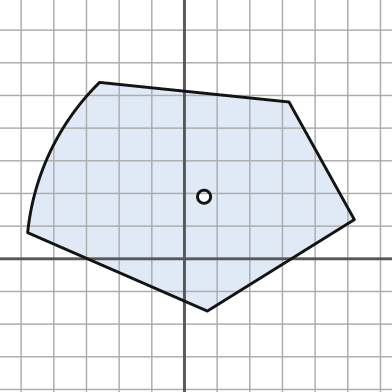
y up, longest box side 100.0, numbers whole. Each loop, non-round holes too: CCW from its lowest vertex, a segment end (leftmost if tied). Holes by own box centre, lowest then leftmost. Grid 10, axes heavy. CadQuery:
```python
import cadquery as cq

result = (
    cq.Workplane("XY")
    .moveTo(7.0, -16.0)
    .lineTo(52.0, 12.0)
    .lineTo(32.0, 48.0)
    .lineTo(-26.0, 54.0)
    .threePointArc((-41.0, 33.0), (-48.0, 8.0))
    .close()
    .moveTo(6.0, 19.0)
    .circle(2.0)
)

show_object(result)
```